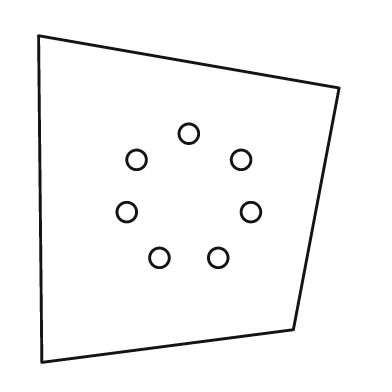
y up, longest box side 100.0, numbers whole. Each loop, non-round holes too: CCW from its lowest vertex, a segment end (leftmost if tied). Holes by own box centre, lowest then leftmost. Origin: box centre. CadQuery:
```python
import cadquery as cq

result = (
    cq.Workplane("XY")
    .moveTo(-45.0, -50.0)
    .lineTo(32.0, -40.0)
    .lineTo(46.0, 34.0)
    .lineTo(-46.0, 50.0)
    .close()
    .moveTo(-9.0, -18.0)
    .circle(3.0)
    .moveTo(9.0, -18.0)
    .circle(3.0)
    .moveTo(-19.0, -4.0)
    .circle(3.0)
    .moveTo(19.0, -4.0)
    .circle(3.0)
    .moveTo(-16.0, 12.0)
    .circle(3.0)
    .moveTo(16.0, 12.0)
    .circle(3.0)
    .moveTo(0.0, 20.0)
    .circle(3.0)
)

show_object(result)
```